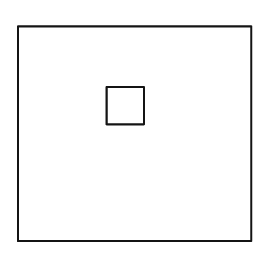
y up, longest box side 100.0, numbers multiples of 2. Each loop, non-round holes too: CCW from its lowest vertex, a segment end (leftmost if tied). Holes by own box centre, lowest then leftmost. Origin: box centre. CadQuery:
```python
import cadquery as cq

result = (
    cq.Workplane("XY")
    .moveTo(-50.0, -46.0)
    .lineTo(50.0, -46.0)
    .lineTo(50.0, 46.0)
    .lineTo(-50.0, 46.0)
    .close()
    .moveTo(-12.0, 4.0)
    .lineTo(4.0, 4.0)
    .lineTo(4.0, 20.0)
    .lineTo(-12.0, 20.0)
    .close()
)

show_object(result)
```